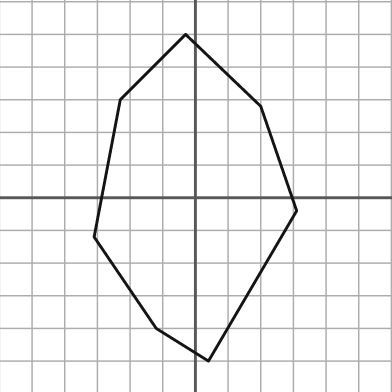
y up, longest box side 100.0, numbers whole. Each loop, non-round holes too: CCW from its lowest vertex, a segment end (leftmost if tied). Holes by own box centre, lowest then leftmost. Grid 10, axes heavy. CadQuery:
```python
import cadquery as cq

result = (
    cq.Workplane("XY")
    .moveTo(4.0, -50.0)
    .lineTo(31.0, -4.0)
    .lineTo(20.0, 28.0)
    .lineTo(-3.0, 50.0)
    .lineTo(-23.0, 30.0)
    .lineTo(-31.0, -12.0)
    .lineTo(-12.0, -40.0)
    .close()
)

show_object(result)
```